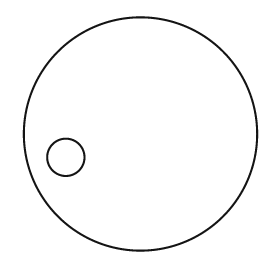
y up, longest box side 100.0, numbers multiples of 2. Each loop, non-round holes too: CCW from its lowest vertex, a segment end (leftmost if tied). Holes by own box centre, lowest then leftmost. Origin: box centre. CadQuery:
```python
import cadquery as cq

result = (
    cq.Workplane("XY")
    .moveTo(0.0, 0.0)
    .circle(50.0)
    .moveTo(-32.0, -10.0)
    .circle(8.0)
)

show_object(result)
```